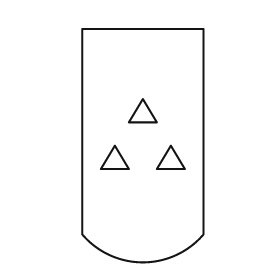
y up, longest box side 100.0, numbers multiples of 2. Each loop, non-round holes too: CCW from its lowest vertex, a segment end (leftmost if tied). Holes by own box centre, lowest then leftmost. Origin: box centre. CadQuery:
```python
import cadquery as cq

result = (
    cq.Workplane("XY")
    .moveTo(-26.0, -38.0)
    .threePointArc((0.0, -50.0), (26.0, -38.0))
    .lineTo(26.0, 50.0)
    .lineTo(-26.0, 50.0)
    .close()
    .moveTo(-18.0, -10.0)
    .lineTo(-6.0, -10.0)
    .lineTo(-12.0, 0.0)
    .close()
    .moveTo(6.0, -10.0)
    .lineTo(18.0, -10.0)
    .lineTo(12.0, 0.0)
    .close()
    .moveTo(-6.0, 10.0)
    .lineTo(6.0, 10.0)
    .lineTo(0.0, 20.0)
    .close()
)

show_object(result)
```